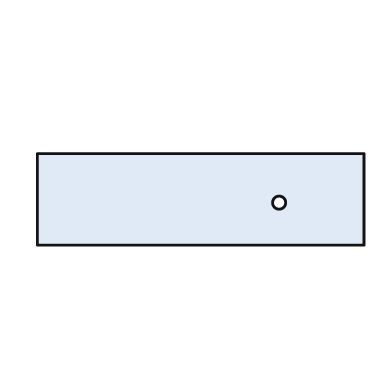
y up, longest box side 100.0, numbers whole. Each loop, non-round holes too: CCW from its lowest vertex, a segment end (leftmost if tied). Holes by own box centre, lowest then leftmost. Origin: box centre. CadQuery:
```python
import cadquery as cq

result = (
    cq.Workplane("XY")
    .moveTo(-50.0, -14.0)
    .lineTo(50.0, -14.0)
    .lineTo(50.0, 14.0)
    .lineTo(-50.0, 14.0)
    .close()
    .moveTo(24.0, -1.0)
    .circle(2.0)
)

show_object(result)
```